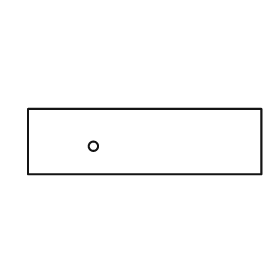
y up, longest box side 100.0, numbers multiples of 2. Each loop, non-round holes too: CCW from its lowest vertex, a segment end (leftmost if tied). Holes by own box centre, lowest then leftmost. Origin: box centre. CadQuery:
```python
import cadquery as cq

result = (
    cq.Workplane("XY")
    .moveTo(-50.0, -14.0)
    .lineTo(50.0, -14.0)
    .lineTo(50.0, 14.0)
    .lineTo(-50.0, 14.0)
    .close()
    .moveTo(-22.0, -2.0)
    .circle(2.0)
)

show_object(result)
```